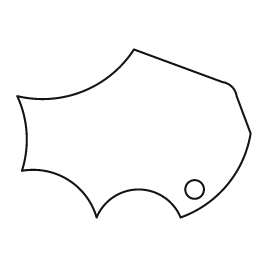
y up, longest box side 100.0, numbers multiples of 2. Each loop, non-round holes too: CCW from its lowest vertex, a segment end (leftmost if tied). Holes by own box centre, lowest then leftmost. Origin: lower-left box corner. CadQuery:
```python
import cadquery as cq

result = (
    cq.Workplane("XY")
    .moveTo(34.0, 0.0)
    .threePointArc((52.0, 12.0), (70.0, 0.0))
    .threePointArc((90.0, 14.0), (100.0, 36.0))
    .lineTo(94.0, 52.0)
    .threePointArc((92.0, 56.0), (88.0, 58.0))
    .lineTo(50.0, 72.0)
    .threePointArc((28.0, 54.0), (0.0, 52.0))
    .threePointArc((4.0, 36.0), (2.0, 20.0))
    .threePointArc((22.0, 16.0), (34.0, 0.0))
    .close()
    .moveTo(76.0, 12.0)
    .circle(4.0)
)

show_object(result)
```